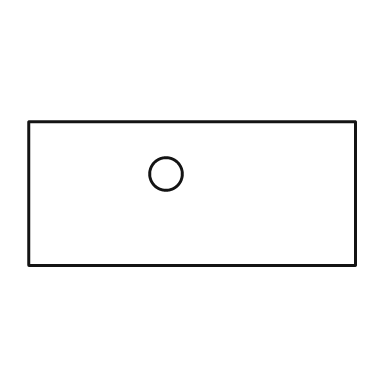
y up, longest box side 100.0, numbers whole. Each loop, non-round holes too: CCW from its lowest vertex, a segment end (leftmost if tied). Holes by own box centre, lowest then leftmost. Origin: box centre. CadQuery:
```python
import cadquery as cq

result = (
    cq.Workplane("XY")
    .moveTo(-50.0, -22.0)
    .lineTo(50.0, -22.0)
    .lineTo(50.0, 22.0)
    .lineTo(-50.0, 22.0)
    .close()
    .moveTo(-8.0, 6.0)
    .circle(5.0)
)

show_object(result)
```